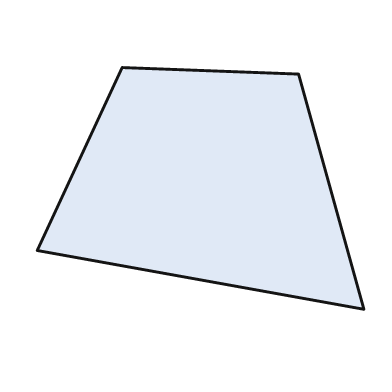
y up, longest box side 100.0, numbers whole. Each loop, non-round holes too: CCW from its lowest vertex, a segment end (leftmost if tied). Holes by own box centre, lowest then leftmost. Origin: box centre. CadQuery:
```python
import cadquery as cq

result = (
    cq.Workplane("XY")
    .moveTo(50.0, -37.0)
    .lineTo(30.0, 35.0)
    .lineTo(-24.0, 37.0)
    .lineTo(-50.0, -19.0)
    .close()
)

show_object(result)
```